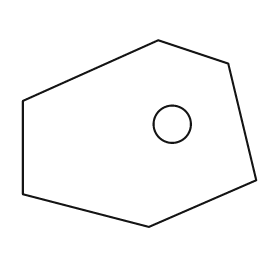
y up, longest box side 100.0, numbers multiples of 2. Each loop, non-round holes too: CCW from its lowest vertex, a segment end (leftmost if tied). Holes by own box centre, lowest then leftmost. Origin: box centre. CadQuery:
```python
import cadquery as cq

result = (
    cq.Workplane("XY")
    .moveTo(4.0, -40.0)
    .lineTo(50.0, -20.0)
    .lineTo(38.0, 30.0)
    .lineTo(8.0, 40.0)
    .lineTo(-50.0, 14.0)
    .lineTo(-50.0, -26.0)
    .close()
    .moveTo(14.0, 4.0)
    .circle(8.0)
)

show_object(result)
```